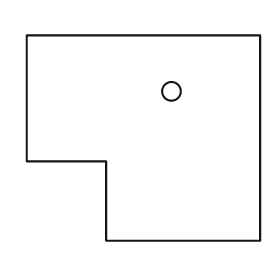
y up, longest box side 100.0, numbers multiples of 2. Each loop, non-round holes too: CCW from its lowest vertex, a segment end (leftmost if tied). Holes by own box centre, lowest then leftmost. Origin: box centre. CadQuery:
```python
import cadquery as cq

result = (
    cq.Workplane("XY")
    .moveTo(-16.0, -44.0)
    .lineTo(50.0, -44.0)
    .lineTo(50.0, 44.0)
    .lineTo(-50.0, 44.0)
    .lineTo(-50.0, -10.0)
    .lineTo(-16.0, -10.0)
    .close()
    .moveTo(12.0, 20.0)
    .circle(4.0)
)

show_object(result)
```